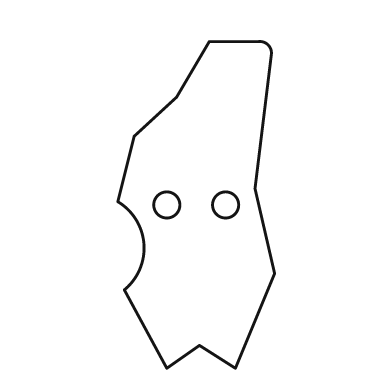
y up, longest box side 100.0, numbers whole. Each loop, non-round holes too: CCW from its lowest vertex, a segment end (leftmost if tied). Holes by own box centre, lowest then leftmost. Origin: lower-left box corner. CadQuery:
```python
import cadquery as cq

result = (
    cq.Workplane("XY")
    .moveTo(15.0, 0.0)
    .lineTo(25.0, 7.0)
    .lineTo(36.0, 0.0)
    .lineTo(48.0, 29.0)
    .lineTo(42.0, 55.0)
    .lineTo(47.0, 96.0)
    .threePointArc((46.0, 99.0), (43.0, 100.0))
    .lineTo(28.0, 100.0)
    .lineTo(18.0, 83.0)
    .lineTo(5.0, 71.0)
    .lineTo(0.0, 51.0)
    .threePointArc((8.0, 38.0), (2.0, 24.0))
    .close()
    .moveTo(15.0, 50.0)
    .circle(4.0)
    .moveTo(33.0, 50.0)
    .circle(4.0)
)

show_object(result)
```